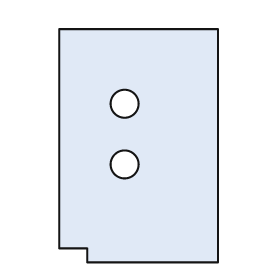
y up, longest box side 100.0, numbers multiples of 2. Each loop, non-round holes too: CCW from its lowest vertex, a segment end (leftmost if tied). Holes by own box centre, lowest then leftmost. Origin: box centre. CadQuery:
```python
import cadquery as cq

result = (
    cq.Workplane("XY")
    .moveTo(-22.0, -50.0)
    .lineTo(34.0, -50.0)
    .lineTo(34.0, 50.0)
    .lineTo(-34.0, 50.0)
    .lineTo(-34.0, -44.0)
    .lineTo(-22.0, -44.0)
    .close()
    .moveTo(-6.0, -8.0)
    .circle(6.0)
    .moveTo(-6.0, 18.0)
    .circle(6.0)
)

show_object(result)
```